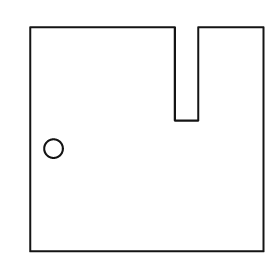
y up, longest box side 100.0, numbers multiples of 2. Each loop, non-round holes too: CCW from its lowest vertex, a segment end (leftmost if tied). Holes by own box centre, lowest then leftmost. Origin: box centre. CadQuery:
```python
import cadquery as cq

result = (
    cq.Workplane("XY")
    .moveTo(-50.0, -48.0)
    .lineTo(50.0, -48.0)
    .lineTo(50.0, 48.0)
    .lineTo(22.0, 48.0)
    .lineTo(22.0, 8.0)
    .lineTo(12.0, 8.0)
    .lineTo(12.0, 48.0)
    .lineTo(-50.0, 48.0)
    .close()
    .moveTo(-40.0, -4.0)
    .circle(4.0)
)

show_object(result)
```